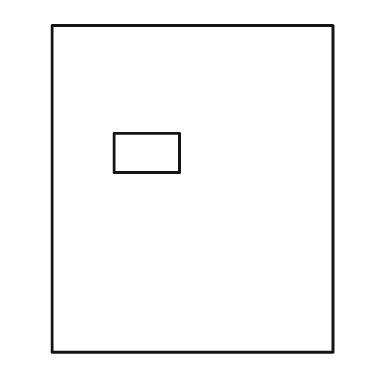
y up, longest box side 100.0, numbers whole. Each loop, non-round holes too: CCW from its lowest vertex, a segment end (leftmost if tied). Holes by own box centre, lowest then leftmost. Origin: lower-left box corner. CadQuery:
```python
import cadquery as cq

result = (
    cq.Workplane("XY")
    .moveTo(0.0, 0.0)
    .lineTo(86.0, 0.0)
    .lineTo(86.0, 100.0)
    .lineTo(0.0, 100.0)
    .close()
    .moveTo(19.0, 55.0)
    .lineTo(39.0, 55.0)
    .lineTo(39.0, 67.0)
    .lineTo(19.0, 67.0)
    .close()
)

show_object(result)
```